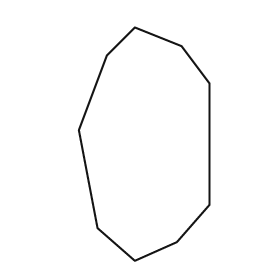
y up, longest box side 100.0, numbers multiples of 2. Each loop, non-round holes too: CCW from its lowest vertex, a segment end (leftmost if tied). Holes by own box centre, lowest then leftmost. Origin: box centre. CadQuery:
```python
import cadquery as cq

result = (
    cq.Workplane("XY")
    .moveTo(-4.0, -50.0)
    .lineTo(14.0, -42.0)
    .lineTo(28.0, -26.0)
    .lineTo(28.0, 26.0)
    .lineTo(16.0, 42.0)
    .lineTo(-4.0, 50.0)
    .lineTo(-16.0, 38.0)
    .lineTo(-28.0, 6.0)
    .lineTo(-20.0, -36.0)
    .close()
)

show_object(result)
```